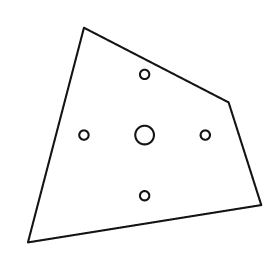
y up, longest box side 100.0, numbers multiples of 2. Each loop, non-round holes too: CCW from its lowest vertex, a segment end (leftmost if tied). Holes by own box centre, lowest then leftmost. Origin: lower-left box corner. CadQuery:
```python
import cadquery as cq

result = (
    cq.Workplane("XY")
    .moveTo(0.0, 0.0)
    .lineTo(100.0, 16.0)
    .lineTo(86.0, 60.0)
    .lineTo(24.0, 92.0)
    .close()
    .moveTo(50.0, 20.0)
    .circle(2.0)
    .moveTo(24.0, 46.0)
    .circle(2.0)
    .moveTo(50.0, 46.0)
    .circle(4.0)
    .moveTo(76.0, 46.0)
    .circle(2.0)
    .moveTo(50.0, 72.0)
    .circle(2.0)
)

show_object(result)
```